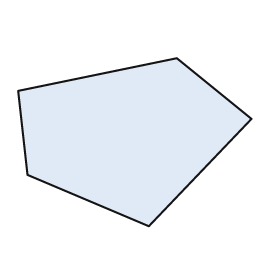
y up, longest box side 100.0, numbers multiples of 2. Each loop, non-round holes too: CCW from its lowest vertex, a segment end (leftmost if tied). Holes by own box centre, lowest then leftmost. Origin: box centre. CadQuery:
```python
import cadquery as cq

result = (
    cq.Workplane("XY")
    .moveTo(6.0, -36.0)
    .lineTo(50.0, 10.0)
    .lineTo(18.0, 36.0)
    .lineTo(-50.0, 22.0)
    .lineTo(-46.0, -14.0)
    .close()
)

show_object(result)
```